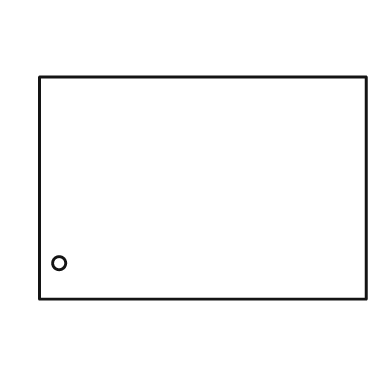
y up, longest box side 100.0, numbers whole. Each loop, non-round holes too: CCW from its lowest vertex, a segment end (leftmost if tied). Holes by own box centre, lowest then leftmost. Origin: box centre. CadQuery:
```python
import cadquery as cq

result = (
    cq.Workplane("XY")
    .moveTo(-50.0, -34.0)
    .lineTo(50.0, -34.0)
    .lineTo(50.0, 34.0)
    .lineTo(-50.0, 34.0)
    .close()
    .moveTo(-44.0, -23.0)
    .circle(2.0)
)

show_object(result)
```